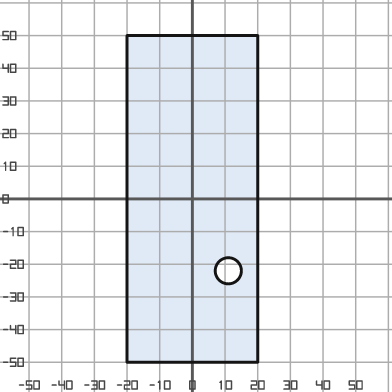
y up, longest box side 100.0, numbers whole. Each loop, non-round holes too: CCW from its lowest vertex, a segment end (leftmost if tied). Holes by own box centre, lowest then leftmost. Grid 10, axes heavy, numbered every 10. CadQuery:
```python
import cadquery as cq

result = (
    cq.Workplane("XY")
    .moveTo(-20.0, -50.0)
    .lineTo(20.0, -50.0)
    .lineTo(20.0, 50.0)
    .lineTo(-20.0, 50.0)
    .close()
    .moveTo(11.0, -22.0)
    .circle(4.0)
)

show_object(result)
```